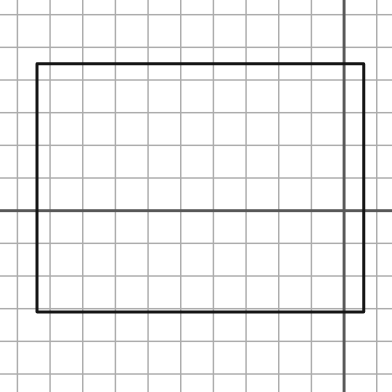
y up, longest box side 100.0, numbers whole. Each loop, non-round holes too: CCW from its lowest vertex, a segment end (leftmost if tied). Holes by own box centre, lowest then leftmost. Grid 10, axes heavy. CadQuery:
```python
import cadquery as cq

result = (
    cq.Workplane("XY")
    .moveTo(-94.0, -31.0)
    .lineTo(6.0, -31.0)
    .lineTo(6.0, 45.0)
    .lineTo(-94.0, 45.0)
    .close()
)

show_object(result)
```